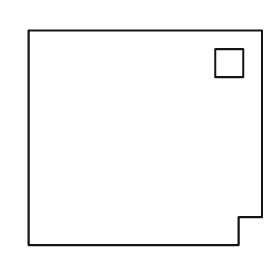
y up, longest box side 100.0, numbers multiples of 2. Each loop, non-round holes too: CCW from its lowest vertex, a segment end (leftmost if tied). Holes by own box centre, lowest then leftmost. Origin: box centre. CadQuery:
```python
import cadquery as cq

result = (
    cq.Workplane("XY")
    .moveTo(-50.0, -46.0)
    .lineTo(40.0, -46.0)
    .lineTo(40.0, -34.0)
    .lineTo(50.0, -34.0)
    .lineTo(50.0, 46.0)
    .lineTo(-50.0, 46.0)
    .close()
    .moveTo(30.0, 26.0)
    .lineTo(42.0, 26.0)
    .lineTo(42.0, 38.0)
    .lineTo(30.0, 38.0)
    .close()
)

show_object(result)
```